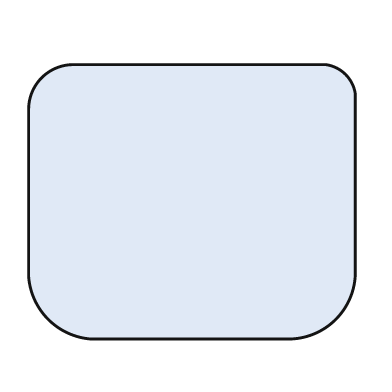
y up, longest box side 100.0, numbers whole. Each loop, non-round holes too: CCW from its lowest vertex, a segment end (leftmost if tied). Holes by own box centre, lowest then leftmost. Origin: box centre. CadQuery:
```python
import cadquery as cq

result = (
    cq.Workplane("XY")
    .moveTo(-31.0, -42.0)
    .lineTo(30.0, -42.0)
    .threePointArc((44.0, -36.0), (50.0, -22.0))
    .lineTo(50.0, 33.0)
    .threePointArc((47.0, 39.0), (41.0, 42.0))
    .lineTo(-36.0, 42.0)
    .threePointArc((-46.0, 38.0), (-50.0, 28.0))
    .lineTo(-50.0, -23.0)
    .threePointArc((-44.0, -36.0), (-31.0, -42.0))
    .close()
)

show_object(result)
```